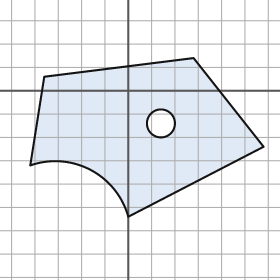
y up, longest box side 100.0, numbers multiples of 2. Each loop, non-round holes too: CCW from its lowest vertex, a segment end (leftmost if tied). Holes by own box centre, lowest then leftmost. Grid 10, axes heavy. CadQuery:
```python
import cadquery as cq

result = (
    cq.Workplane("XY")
    .moveTo(0.0, -54.0)
    .lineTo(58.0, -24.0)
    .lineTo(28.0, 14.0)
    .lineTo(-36.0, 6.0)
    .lineTo(-42.0, -32.0)
    .threePointArc((-16.0, -34.0), (0.0, -54.0))
    .close()
    .moveTo(14.0, -14.0)
    .circle(6.0)
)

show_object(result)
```